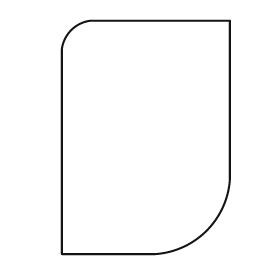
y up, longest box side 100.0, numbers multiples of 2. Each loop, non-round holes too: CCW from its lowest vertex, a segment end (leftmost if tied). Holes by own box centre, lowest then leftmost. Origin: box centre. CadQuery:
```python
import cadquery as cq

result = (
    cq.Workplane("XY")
    .moveTo(-36.0, -50.0)
    .lineTo(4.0, -50.0)
    .threePointArc((26.0, -40.0), (36.0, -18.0))
    .lineTo(36.0, 50.0)
    .lineTo(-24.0, 50.0)
    .threePointArc((-32.0, 46.0), (-36.0, 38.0))
    .close()
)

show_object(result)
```